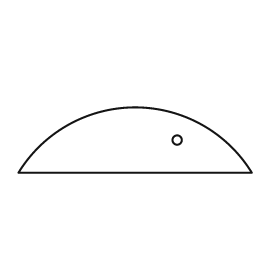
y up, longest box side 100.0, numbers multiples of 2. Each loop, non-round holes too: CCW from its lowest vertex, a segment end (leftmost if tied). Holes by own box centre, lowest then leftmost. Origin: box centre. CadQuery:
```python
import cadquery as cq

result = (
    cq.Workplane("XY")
    .moveTo(-50.0, -14.0)
    .lineTo(50.0, -14.0)
    .threePointArc((0.0, 14.0), (-50.0, -14.0))
    .close()
    .moveTo(18.0, 0.0)
    .circle(2.0)
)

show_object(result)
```